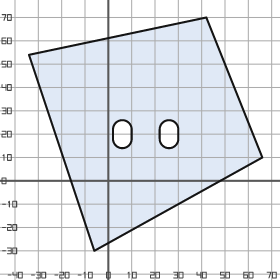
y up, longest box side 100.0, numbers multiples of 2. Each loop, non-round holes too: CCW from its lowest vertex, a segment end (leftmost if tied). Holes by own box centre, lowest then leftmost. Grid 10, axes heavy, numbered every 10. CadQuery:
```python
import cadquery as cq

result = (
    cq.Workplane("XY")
    .moveTo(-6.0, -30.0)
    .lineTo(66.0, 10.0)
    .lineTo(42.0, 70.0)
    .lineTo(-34.0, 54.0)
    .close()
    .moveTo(2.0, 18.0)
    .threePointArc((6.0, 14.0), (10.0, 18.0))
    .lineTo(10.0, 22.0)
    .threePointArc((6.0, 26.0), (2.0, 22.0))
    .close()
    .moveTo(22.0, 18.0)
    .threePointArc((26.0, 14.0), (30.0, 18.0))
    .lineTo(30.0, 22.0)
    .threePointArc((26.0, 26.0), (22.0, 22.0))
    .close()
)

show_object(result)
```